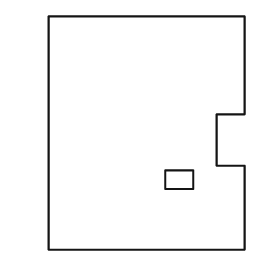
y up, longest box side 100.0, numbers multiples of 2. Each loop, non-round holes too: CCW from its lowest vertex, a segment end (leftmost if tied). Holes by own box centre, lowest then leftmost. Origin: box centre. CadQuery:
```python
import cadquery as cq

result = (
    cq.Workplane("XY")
    .moveTo(-42.0, -50.0)
    .lineTo(42.0, -50.0)
    .lineTo(42.0, -14.0)
    .lineTo(30.0, -14.0)
    .lineTo(30.0, 8.0)
    .lineTo(42.0, 8.0)
    .lineTo(42.0, 50.0)
    .lineTo(-42.0, 50.0)
    .close()
    .moveTo(8.0, -24.0)
    .lineTo(20.0, -24.0)
    .lineTo(20.0, -16.0)
    .lineTo(8.0, -16.0)
    .close()
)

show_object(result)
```